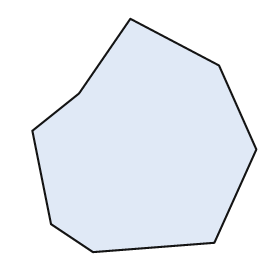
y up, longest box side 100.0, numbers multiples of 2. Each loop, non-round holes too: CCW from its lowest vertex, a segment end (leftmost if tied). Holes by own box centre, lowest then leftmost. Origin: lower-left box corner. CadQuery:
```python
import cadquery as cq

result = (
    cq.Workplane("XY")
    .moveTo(26.0, 0.0)
    .lineTo(78.0, 4.0)
    .lineTo(96.0, 44.0)
    .lineTo(80.0, 80.0)
    .lineTo(42.0, 100.0)
    .lineTo(20.0, 68.0)
    .lineTo(0.0, 52.0)
    .lineTo(8.0, 12.0)
    .close()
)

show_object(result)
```